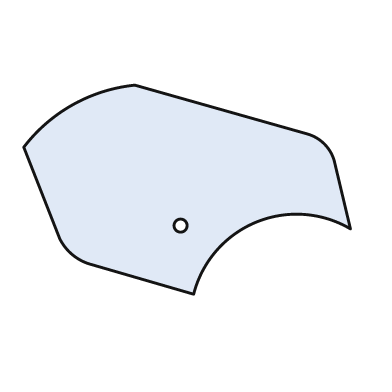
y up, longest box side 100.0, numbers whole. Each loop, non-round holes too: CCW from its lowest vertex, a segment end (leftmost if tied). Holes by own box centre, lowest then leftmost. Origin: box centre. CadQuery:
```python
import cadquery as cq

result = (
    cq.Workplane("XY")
    .moveTo(2.0, -32.0)
    .threePointArc((21.0, -10.0), (50.0, -12.0))
    .lineTo(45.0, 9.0)
    .threePointArc((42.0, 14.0), (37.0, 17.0))
    .lineTo(-16.0, 32.0)
    .threePointArc((-35.0, 26.0), (-50.0, 13.0))
    .lineTo(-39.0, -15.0)
    .threePointArc((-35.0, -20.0), (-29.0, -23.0))
    .close()
    .moveTo(-2.0, -11.0)
    .circle(2.0)
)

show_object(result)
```